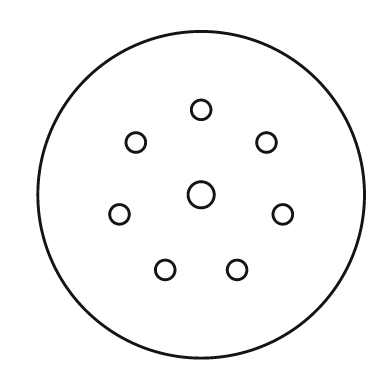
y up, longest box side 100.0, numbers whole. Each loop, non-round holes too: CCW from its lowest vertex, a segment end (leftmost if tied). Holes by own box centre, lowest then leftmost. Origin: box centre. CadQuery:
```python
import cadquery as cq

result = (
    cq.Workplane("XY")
    .moveTo(0.0, 0.0)
    .circle(50.0)
    .moveTo(-11.0, -23.0)
    .circle(3.0)
    .moveTo(11.0, -23.0)
    .circle(3.0)
    .moveTo(-25.0, -6.0)
    .circle(3.0)
    .moveTo(25.0, -6.0)
    .circle(3.0)
    .moveTo(0.0, 0.0)
    .circle(4.0)
    .moveTo(-20.0, 16.0)
    .circle(3.0)
    .moveTo(20.0, 16.0)
    .circle(3.0)
    .moveTo(0.0, 26.0)
    .circle(3.0)
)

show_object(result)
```